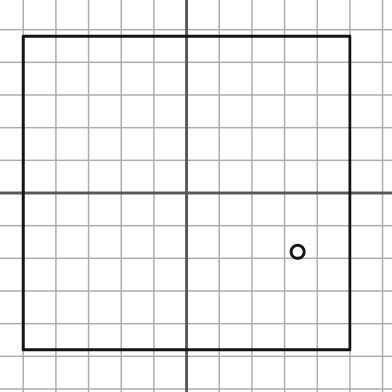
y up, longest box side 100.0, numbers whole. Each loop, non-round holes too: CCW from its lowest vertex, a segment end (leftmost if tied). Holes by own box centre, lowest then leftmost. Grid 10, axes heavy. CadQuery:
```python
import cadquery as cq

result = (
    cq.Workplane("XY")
    .moveTo(-50.0, -48.0)
    .lineTo(50.0, -48.0)
    .lineTo(50.0, 48.0)
    .lineTo(-50.0, 48.0)
    .close()
    .moveTo(34.0, -18.0)
    .circle(2.0)
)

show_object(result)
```